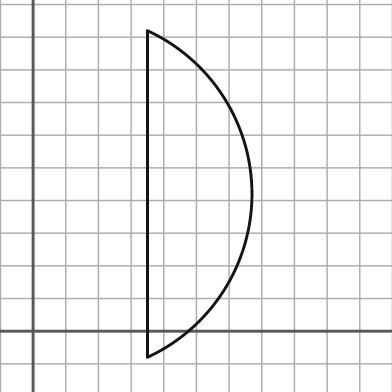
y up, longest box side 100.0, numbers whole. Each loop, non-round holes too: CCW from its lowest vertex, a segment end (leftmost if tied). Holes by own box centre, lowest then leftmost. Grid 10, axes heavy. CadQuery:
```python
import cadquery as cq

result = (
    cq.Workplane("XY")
    .moveTo(35.0, -8.0)
    .threePointArc((67.0, 42.0), (35.0, 92.0))
    .close()
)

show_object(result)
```